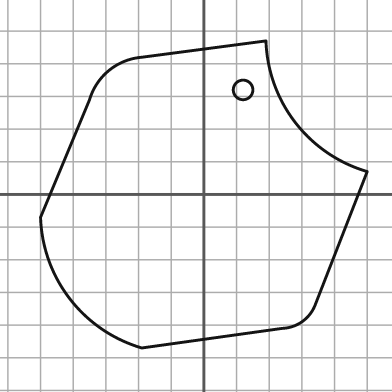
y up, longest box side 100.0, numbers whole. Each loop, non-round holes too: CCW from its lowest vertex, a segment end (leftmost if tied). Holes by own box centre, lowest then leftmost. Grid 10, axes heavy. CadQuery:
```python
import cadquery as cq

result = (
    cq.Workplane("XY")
    .moveTo(-19.0, -47.0)
    .lineTo(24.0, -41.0)
    .threePointArc((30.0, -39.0), (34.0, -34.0))
    .lineTo(50.0, 7.0)
    .threePointArc((28.0, 22.0), (19.0, 47.0))
    .lineTo(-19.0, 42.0)
    .threePointArc((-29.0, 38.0), (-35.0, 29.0))
    .lineTo(-50.0, -7.0)
    .threePointArc((-41.0, -32.0), (-19.0, -47.0))
    .close()
    .moveTo(12.0, 32.0)
    .circle(3.0)
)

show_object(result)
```